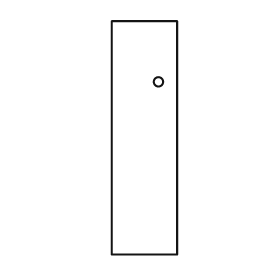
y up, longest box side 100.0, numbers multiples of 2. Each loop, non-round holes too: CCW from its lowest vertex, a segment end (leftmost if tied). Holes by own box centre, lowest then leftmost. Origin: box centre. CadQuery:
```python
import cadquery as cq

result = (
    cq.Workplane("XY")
    .moveTo(-14.0, -50.0)
    .lineTo(14.0, -50.0)
    .lineTo(14.0, 50.0)
    .lineTo(-14.0, 50.0)
    .close()
    .moveTo(6.0, 24.0)
    .circle(2.0)
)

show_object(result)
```